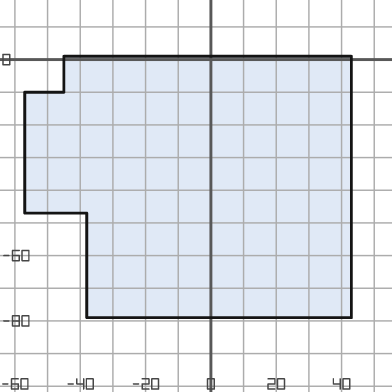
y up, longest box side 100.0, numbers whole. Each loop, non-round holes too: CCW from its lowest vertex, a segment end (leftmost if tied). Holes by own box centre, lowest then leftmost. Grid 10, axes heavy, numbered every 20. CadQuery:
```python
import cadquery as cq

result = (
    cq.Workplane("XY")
    .moveTo(-38.0, -79.0)
    .lineTo(43.0, -79.0)
    .lineTo(43.0, 1.0)
    .lineTo(-45.0, 1.0)
    .lineTo(-45.0, -10.0)
    .lineTo(-57.0, -10.0)
    .lineTo(-57.0, -47.0)
    .lineTo(-38.0, -47.0)
    .close()
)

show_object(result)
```